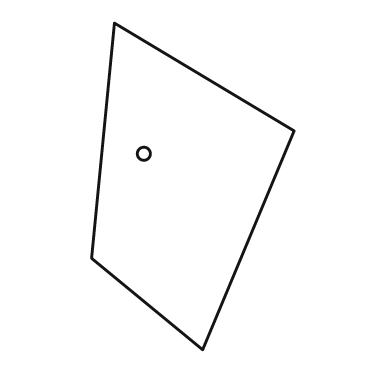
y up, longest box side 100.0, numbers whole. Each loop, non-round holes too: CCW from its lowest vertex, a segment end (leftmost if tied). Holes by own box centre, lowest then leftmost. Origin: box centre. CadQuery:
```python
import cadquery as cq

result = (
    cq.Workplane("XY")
    .moveTo(3.0, -50.0)
    .lineTo(31.0, 17.0)
    .lineTo(-24.0, 50.0)
    .lineTo(-31.0, -22.0)
    .close()
    .moveTo(-15.0, 10.0)
    .circle(2.0)
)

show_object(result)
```